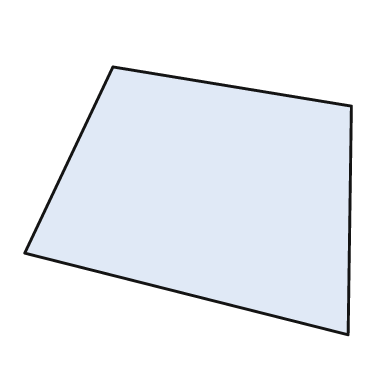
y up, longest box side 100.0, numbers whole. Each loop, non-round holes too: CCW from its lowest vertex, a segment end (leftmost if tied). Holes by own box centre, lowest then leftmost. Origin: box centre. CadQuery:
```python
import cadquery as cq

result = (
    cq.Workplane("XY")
    .moveTo(49.0, -41.0)
    .lineTo(50.0, 29.0)
    .lineTo(-23.0, 41.0)
    .lineTo(-50.0, -16.0)
    .close()
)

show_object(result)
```